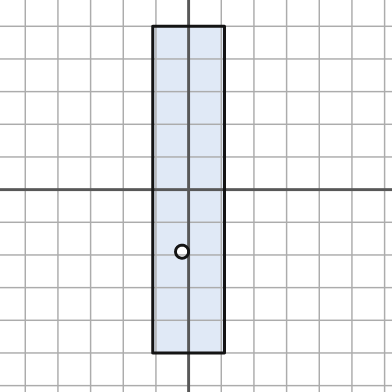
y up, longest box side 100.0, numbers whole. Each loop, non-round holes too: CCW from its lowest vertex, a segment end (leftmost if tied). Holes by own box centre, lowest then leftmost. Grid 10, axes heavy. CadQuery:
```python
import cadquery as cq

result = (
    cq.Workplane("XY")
    .moveTo(-11.0, -50.0)
    .lineTo(11.0, -50.0)
    .lineTo(11.0, 50.0)
    .lineTo(-11.0, 50.0)
    .close()
    .moveTo(-2.0, -19.0)
    .circle(2.0)
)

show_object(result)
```